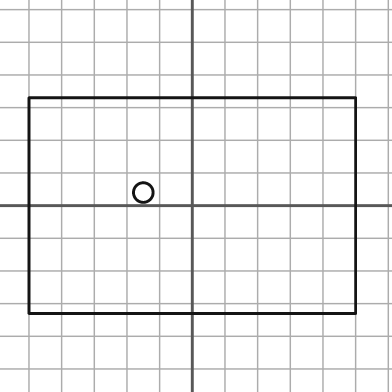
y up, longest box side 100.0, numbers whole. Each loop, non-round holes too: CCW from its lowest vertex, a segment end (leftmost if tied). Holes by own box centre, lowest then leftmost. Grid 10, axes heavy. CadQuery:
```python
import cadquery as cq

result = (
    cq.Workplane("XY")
    .moveTo(-50.0, -33.0)
    .lineTo(50.0, -33.0)
    .lineTo(50.0, 33.0)
    .lineTo(-50.0, 33.0)
    .close()
    .moveTo(-15.0, 4.0)
    .circle(3.0)
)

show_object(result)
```